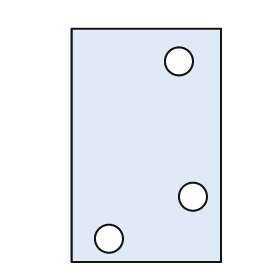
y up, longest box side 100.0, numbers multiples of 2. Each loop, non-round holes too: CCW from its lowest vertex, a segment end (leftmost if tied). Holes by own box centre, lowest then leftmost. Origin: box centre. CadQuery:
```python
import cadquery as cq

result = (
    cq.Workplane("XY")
    .moveTo(-32.0, -50.0)
    .lineTo(32.0, -50.0)
    .lineTo(32.0, 50.0)
    .lineTo(-32.0, 50.0)
    .close()
    .moveTo(-16.0, -40.0)
    .circle(6.0)
    .moveTo(20.0, -22.0)
    .circle(6.0)
    .moveTo(14.0, 36.0)
    .circle(6.0)
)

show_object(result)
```